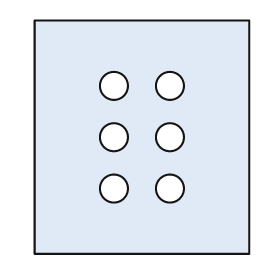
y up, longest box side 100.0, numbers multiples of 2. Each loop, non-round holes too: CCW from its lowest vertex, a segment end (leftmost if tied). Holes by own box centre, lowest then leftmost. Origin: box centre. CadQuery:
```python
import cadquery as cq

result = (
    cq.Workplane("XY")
    .moveTo(-46.0, -50.0)
    .lineTo(46.0, -50.0)
    .lineTo(46.0, 50.0)
    .lineTo(-46.0, 50.0)
    .close()
    .moveTo(-12.0, -22.0)
    .circle(6.0)
    .moveTo(12.0, -22.0)
    .circle(6.0)
    .moveTo(-12.0, 0.0)
    .circle(6.0)
    .moveTo(12.0, 0.0)
    .circle(6.0)
    .moveTo(-12.0, 22.0)
    .circle(6.0)
    .moveTo(12.0, 22.0)
    .circle(6.0)
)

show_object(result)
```